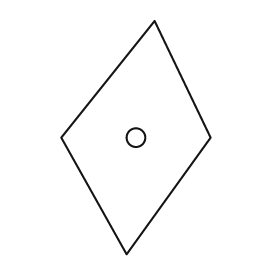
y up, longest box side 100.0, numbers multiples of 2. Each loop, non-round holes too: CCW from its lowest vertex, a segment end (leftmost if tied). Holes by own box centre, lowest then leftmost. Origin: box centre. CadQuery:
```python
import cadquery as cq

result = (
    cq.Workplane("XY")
    .moveTo(-4.0, -50.0)
    .lineTo(32.0, 0.0)
    .lineTo(8.0, 50.0)
    .lineTo(-32.0, 0.0)
    .close()
    .moveTo(0.0, 0.0)
    .circle(4.0)
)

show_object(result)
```